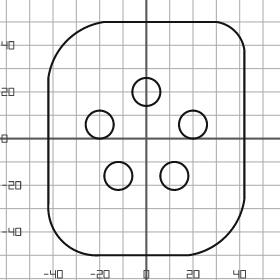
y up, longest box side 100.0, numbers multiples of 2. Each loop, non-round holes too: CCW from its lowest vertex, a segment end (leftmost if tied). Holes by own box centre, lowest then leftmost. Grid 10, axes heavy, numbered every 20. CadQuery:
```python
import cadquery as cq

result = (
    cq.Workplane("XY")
    .moveTo(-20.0, -50.0)
    .lineTo(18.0, -50.0)
    .threePointArc((34.0, -42.0), (42.0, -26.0))
    .lineTo(42.0, 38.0)
    .threePointArc((38.0, 46.0), (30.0, 50.0))
    .lineTo(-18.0, 50.0)
    .threePointArc((-34.0, 42.0), (-42.0, 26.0))
    .lineTo(-42.0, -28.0)
    .threePointArc((-36.0, -44.0), (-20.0, -50.0))
    .close()
    .moveTo(-12.0, -16.0)
    .circle(6.0)
    .moveTo(12.0, -16.0)
    .circle(6.0)
    .moveTo(-20.0, 6.0)
    .circle(6.0)
    .moveTo(20.0, 6.0)
    .circle(6.0)
    .moveTo(0.0, 20.0)
    .circle(6.0)
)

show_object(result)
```